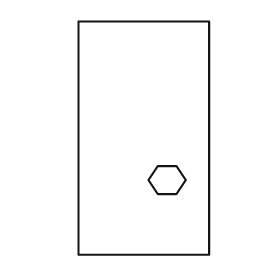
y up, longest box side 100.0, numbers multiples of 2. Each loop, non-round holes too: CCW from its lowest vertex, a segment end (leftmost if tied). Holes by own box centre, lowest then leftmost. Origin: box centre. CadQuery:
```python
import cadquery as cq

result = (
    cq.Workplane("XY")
    .moveTo(-28.0, -50.0)
    .lineTo(28.0, -50.0)
    .lineTo(28.0, 50.0)
    .lineTo(-28.0, 50.0)
    .close()
    .moveTo(6.0, -24.0)
    .lineTo(14.0, -24.0)
    .lineTo(18.0, -18.0)
    .lineTo(14.0, -12.0)
    .lineTo(6.0, -12.0)
    .lineTo(2.0, -18.0)
    .close()
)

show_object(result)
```